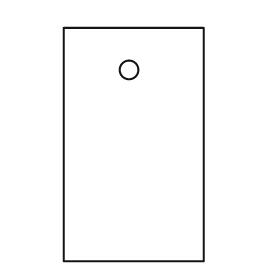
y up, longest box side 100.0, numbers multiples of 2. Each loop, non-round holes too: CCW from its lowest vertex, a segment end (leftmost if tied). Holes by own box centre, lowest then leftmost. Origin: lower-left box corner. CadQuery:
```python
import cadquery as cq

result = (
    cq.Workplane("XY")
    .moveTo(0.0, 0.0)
    .lineTo(60.0, 0.0)
    .lineTo(60.0, 100.0)
    .lineTo(0.0, 100.0)
    .close()
    .moveTo(28.0, 82.0)
    .circle(4.0)
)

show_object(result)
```